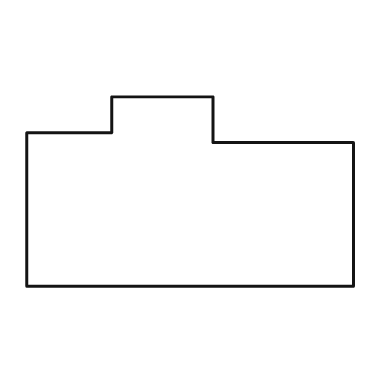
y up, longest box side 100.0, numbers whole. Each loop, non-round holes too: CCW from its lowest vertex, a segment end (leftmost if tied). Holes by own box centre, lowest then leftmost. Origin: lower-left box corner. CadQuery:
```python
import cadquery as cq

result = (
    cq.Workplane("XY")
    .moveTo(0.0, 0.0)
    .lineTo(100.0, 0.0)
    .lineTo(100.0, 44.0)
    .lineTo(57.0, 44.0)
    .lineTo(57.0, 58.0)
    .lineTo(26.0, 58.0)
    .lineTo(26.0, 47.0)
    .lineTo(0.0, 47.0)
    .close()
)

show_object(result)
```